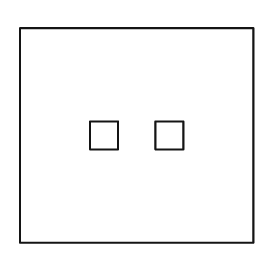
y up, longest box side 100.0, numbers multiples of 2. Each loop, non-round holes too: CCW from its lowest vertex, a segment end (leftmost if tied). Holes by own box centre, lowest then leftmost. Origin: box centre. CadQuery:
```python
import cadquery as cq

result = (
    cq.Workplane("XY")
    .moveTo(-50.0, -46.0)
    .lineTo(50.0, -46.0)
    .lineTo(50.0, 46.0)
    .lineTo(-50.0, 46.0)
    .close()
    .moveTo(-20.0, -6.0)
    .lineTo(-8.0, -6.0)
    .lineTo(-8.0, 6.0)
    .lineTo(-20.0, 6.0)
    .close()
    .moveTo(8.0, -6.0)
    .lineTo(20.0, -6.0)
    .lineTo(20.0, 6.0)
    .lineTo(8.0, 6.0)
    .close()
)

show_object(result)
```